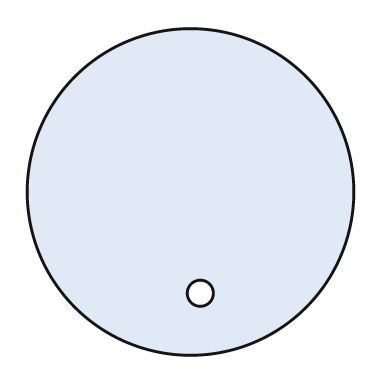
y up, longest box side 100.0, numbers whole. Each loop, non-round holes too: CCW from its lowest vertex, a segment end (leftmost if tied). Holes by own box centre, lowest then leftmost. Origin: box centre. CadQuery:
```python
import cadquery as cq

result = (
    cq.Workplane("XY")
    .moveTo(0.0, 0.0)
    .circle(50.0)
    .moveTo(3.0, -31.0)
    .circle(4.0)
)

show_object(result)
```